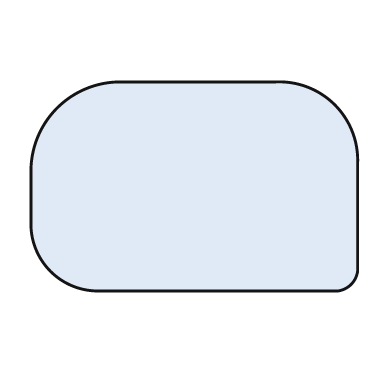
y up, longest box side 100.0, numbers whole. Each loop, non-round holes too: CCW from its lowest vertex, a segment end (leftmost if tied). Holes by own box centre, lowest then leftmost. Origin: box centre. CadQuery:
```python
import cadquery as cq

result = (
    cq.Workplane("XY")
    .moveTo(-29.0, -32.0)
    .lineTo(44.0, -32.0)
    .threePointArc((48.0, -30.0), (50.0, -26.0))
    .lineTo(50.0, 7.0)
    .threePointArc((43.0, 25.0), (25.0, 32.0))
    .lineTo(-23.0, 32.0)
    .threePointArc((-42.0, 24.0), (-50.0, 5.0))
    .lineTo(-50.0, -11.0)
    .threePointArc((-44.0, -26.0), (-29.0, -32.0))
    .close()
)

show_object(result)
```